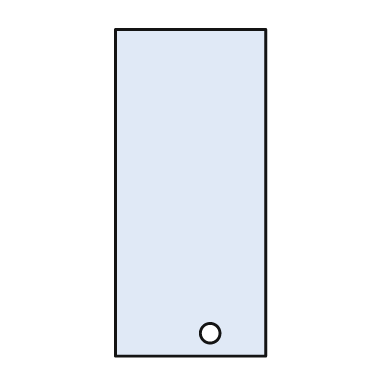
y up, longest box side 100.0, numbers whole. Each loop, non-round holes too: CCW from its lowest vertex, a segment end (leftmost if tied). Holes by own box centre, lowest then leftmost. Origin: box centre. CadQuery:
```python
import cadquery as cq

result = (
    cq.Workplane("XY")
    .moveTo(-23.0, -50.0)
    .lineTo(23.0, -50.0)
    .lineTo(23.0, 50.0)
    .lineTo(-23.0, 50.0)
    .close()
    .moveTo(6.0, -43.0)
    .circle(3.0)
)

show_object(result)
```